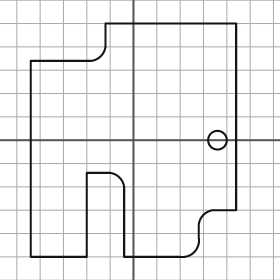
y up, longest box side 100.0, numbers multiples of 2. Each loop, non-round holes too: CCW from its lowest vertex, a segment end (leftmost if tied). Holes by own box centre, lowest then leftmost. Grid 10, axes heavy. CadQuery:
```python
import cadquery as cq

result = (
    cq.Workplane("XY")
    .moveTo(-44.0, -50.0)
    .lineTo(-20.0, -50.0)
    .lineTo(-20.0, -14.0)
    .lineTo(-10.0, -14.0)
    .threePointArc((-6.0, -16.0), (-4.0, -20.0))
    .lineTo(-4.0, -50.0)
    .lineTo(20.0, -50.0)
    .threePointArc((26.0, -48.0), (28.0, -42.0))
    .lineTo(28.0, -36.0)
    .threePointArc((30.0, -32.0), (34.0, -30.0))
    .lineTo(44.0, -30.0)
    .lineTo(44.0, 50.0)
    .lineTo(-12.0, 50.0)
    .lineTo(-12.0, 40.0)
    .threePointArc((-14.0, 36.0), (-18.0, 34.0))
    .lineTo(-44.0, 34.0)
    .close()
    .moveTo(36.0, 0.0)
    .circle(4.0)
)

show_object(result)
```